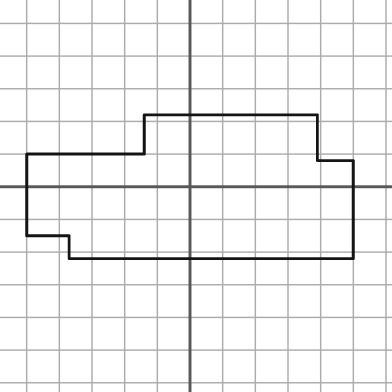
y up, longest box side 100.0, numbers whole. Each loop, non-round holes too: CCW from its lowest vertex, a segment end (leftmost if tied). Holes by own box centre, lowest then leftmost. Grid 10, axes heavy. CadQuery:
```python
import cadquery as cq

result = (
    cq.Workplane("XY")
    .moveTo(-37.0, -22.0)
    .lineTo(50.0, -22.0)
    .lineTo(50.0, 8.0)
    .lineTo(39.0, 8.0)
    .lineTo(39.0, 22.0)
    .lineTo(-14.0, 22.0)
    .lineTo(-14.0, 10.0)
    .lineTo(-50.0, 10.0)
    .lineTo(-50.0, -15.0)
    .lineTo(-37.0, -15.0)
    .close()
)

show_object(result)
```